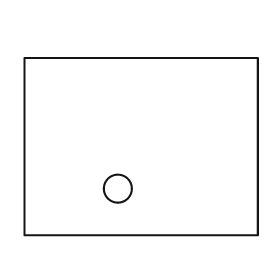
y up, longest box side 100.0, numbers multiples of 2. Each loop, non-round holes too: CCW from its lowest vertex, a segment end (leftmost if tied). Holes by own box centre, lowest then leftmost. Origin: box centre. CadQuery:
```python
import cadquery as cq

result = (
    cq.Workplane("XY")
    .moveTo(-50.0, -38.0)
    .lineTo(50.0, -38.0)
    .lineTo(50.0, 38.0)
    .lineTo(-50.0, 38.0)
    .close()
    .moveTo(-10.0, -18.0)
    .circle(6.0)
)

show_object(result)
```